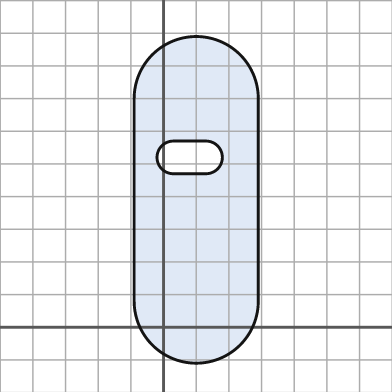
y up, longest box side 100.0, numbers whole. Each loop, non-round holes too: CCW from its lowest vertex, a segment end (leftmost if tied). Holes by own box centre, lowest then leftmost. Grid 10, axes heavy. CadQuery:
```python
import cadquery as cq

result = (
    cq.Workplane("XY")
    .moveTo(-9.0, 8.0)
    .threePointArc((10.0, -11.0), (29.0, 8.0))
    .lineTo(29.0, 70.0)
    .threePointArc((10.0, 89.0), (-9.0, 70.0))
    .close()
    .moveTo(3.0, 47.0)
    .lineTo(13.0, 47.0)
    .threePointArc((18.0, 52.0), (13.0, 57.0))
    .lineTo(3.0, 57.0)
    .threePointArc((-2.0, 52.0), (3.0, 47.0))
    .close()
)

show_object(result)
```